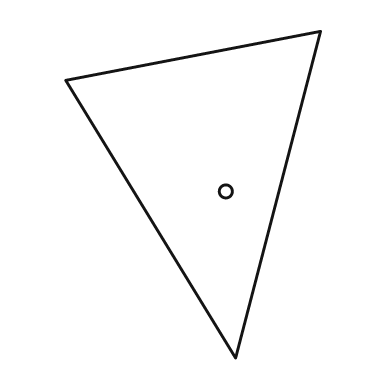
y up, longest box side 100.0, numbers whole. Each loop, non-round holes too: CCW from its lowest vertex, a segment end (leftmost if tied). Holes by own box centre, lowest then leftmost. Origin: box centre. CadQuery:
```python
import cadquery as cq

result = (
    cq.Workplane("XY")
    .moveTo(13.0, -50.0)
    .lineTo(39.0, 50.0)
    .lineTo(-39.0, 35.0)
    .close()
    .moveTo(10.0, 1.0)
    .circle(2.0)
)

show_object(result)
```